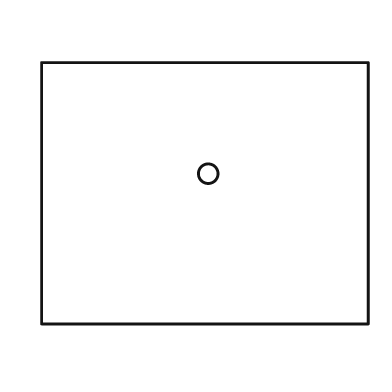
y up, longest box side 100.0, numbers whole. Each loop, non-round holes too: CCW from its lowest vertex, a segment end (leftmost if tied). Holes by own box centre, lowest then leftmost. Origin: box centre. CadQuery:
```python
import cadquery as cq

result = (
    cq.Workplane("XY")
    .moveTo(-50.0, -40.0)
    .lineTo(50.0, -40.0)
    .lineTo(50.0, 40.0)
    .lineTo(-50.0, 40.0)
    .close()
    .moveTo(1.0, 6.0)
    .circle(3.0)
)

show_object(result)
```